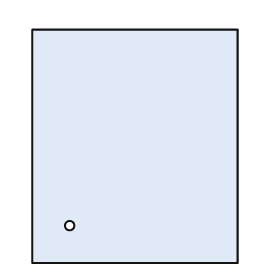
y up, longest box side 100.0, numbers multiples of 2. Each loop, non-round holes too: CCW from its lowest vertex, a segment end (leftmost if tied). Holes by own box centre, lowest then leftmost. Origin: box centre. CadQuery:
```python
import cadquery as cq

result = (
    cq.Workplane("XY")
    .moveTo(-44.0, -50.0)
    .lineTo(44.0, -50.0)
    .lineTo(44.0, 50.0)
    .lineTo(-44.0, 50.0)
    .close()
    .moveTo(-28.0, -34.0)
    .circle(2.0)
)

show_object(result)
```